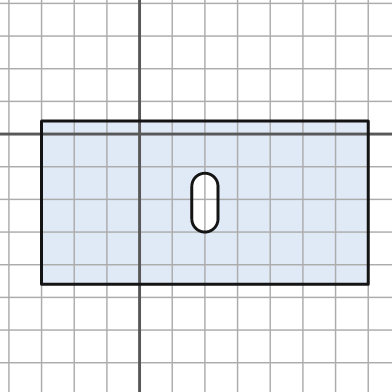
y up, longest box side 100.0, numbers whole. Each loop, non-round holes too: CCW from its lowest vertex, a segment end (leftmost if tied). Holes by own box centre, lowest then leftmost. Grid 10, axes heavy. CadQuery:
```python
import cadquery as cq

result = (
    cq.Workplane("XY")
    .moveTo(-30.0, -46.0)
    .lineTo(70.0, -46.0)
    .lineTo(70.0, 4.0)
    .lineTo(-30.0, 4.0)
    .close()
    .moveTo(16.0, -26.0)
    .threePointArc((20.0, -30.0), (24.0, -26.0))
    .lineTo(24.0, -16.0)
    .threePointArc((20.0, -12.0), (16.0, -16.0))
    .close()
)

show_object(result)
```